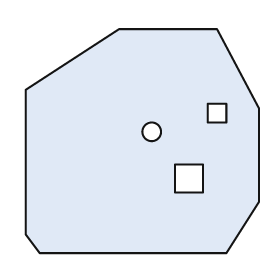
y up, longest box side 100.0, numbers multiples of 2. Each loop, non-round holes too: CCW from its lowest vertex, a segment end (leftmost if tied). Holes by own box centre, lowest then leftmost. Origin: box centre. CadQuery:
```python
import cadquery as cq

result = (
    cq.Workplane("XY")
    .moveTo(-44.0, -48.0)
    .lineTo(36.0, -48.0)
    .lineTo(50.0, -26.0)
    .lineTo(50.0, 14.0)
    .lineTo(32.0, 48.0)
    .lineTo(-10.0, 48.0)
    .lineTo(-50.0, 22.0)
    .lineTo(-50.0, -40.0)
    .close()
    .moveTo(14.0, -22.0)
    .lineTo(26.0, -22.0)
    .lineTo(26.0, -10.0)
    .lineTo(14.0, -10.0)
    .close()
    .moveTo(4.0, 4.0)
    .circle(4.0)
    .moveTo(28.0, 8.0)
    .lineTo(36.0, 8.0)
    .lineTo(36.0, 16.0)
    .lineTo(28.0, 16.0)
    .close()
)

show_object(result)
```